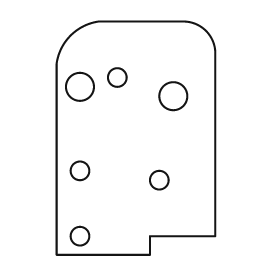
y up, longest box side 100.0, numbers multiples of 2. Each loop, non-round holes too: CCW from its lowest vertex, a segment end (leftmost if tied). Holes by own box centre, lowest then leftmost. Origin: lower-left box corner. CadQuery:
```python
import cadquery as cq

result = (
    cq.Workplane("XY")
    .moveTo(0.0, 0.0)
    .lineTo(40.0, 0.0)
    .lineTo(40.0, 8.0)
    .lineTo(68.0, 8.0)
    .lineTo(68.0, 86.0)
    .threePointArc((64.0, 96.0), (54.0, 100.0))
    .lineTo(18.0, 100.0)
    .threePointArc((6.0, 94.0), (0.0, 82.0))
    .close()
    .moveTo(10.0, 8.0)
    .circle(4.0)
    .moveTo(44.0, 32.0)
    .circle(4.0)
    .moveTo(10.0, 36.0)
    .circle(4.0)
    .moveTo(50.0, 68.0)
    .circle(6.0)
    .moveTo(10.0, 72.0)
    .circle(6.0)
    .moveTo(26.0, 76.0)
    .circle(4.0)
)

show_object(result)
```